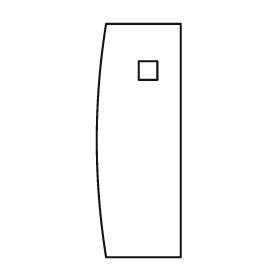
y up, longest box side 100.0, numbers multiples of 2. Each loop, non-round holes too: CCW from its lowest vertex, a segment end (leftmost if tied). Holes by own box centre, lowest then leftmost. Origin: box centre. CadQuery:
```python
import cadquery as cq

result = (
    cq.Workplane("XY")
    .moveTo(-14.0, -50.0)
    .lineTo(18.0, -50.0)
    .lineTo(18.0, 50.0)
    .lineTo(-14.0, 50.0)
    .threePointArc((-18.0, 0.0), (-14.0, -50.0))
    .close()
    .moveTo(0.0, 26.0)
    .lineTo(8.0, 26.0)
    .lineTo(8.0, 34.0)
    .lineTo(0.0, 34.0)
    .close()
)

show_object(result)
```